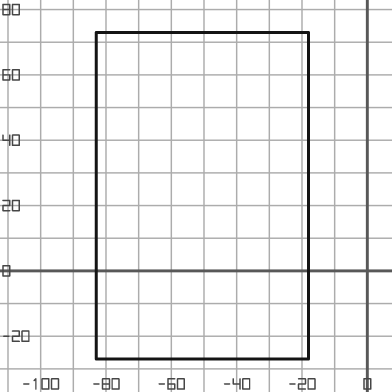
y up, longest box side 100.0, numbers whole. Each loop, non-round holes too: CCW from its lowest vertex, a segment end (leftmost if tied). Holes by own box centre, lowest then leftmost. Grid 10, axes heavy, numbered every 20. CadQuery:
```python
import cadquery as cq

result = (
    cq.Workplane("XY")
    .moveTo(-83.0, -27.0)
    .lineTo(-18.0, -27.0)
    .lineTo(-18.0, 73.0)
    .lineTo(-83.0, 73.0)
    .close()
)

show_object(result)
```